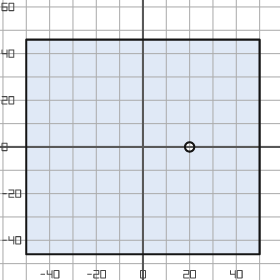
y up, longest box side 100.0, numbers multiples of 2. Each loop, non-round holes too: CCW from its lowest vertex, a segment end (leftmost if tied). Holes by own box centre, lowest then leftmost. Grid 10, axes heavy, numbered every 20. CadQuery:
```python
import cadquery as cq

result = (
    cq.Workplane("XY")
    .moveTo(-50.0, -46.0)
    .lineTo(50.0, -46.0)
    .lineTo(50.0, 46.0)
    .lineTo(-50.0, 46.0)
    .close()
    .moveTo(20.0, 0.0)
    .circle(2.0)
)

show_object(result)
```